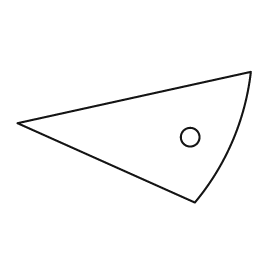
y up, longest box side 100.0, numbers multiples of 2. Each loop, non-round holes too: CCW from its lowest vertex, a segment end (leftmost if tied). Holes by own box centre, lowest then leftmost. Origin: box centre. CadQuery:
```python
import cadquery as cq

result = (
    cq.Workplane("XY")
    .moveTo(26.0, -28.0)
    .threePointArc((42.0, -2.0), (50.0, 28.0))
    .lineTo(-50.0, 6.0)
    .close()
    .moveTo(24.0, 0.0)
    .circle(4.0)
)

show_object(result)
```